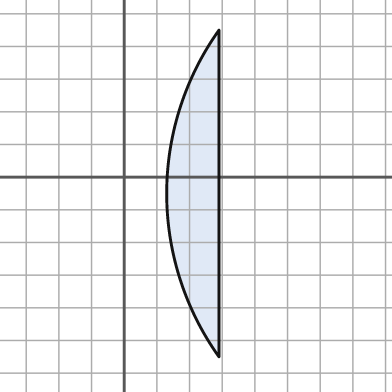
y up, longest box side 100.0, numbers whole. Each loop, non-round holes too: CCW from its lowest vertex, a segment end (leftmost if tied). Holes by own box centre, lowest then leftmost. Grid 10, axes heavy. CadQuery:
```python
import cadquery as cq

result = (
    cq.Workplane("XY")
    .moveTo(29.0, -55.0)
    .lineTo(29.0, 45.0)
    .threePointArc((13.0, -5.0), (29.0, -55.0))
    .close()
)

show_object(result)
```